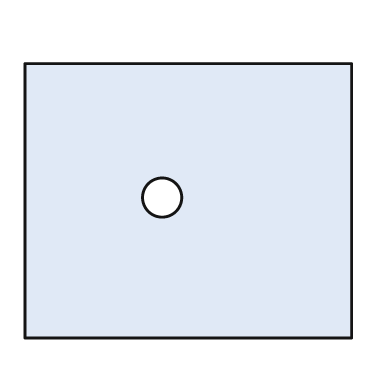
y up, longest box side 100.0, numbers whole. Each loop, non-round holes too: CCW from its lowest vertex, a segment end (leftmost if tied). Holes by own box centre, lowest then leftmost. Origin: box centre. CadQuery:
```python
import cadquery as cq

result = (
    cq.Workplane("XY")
    .moveTo(-50.0, -42.0)
    .lineTo(50.0, -42.0)
    .lineTo(50.0, 42.0)
    .lineTo(-50.0, 42.0)
    .close()
    .moveTo(-8.0, 1.0)
    .circle(6.0)
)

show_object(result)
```